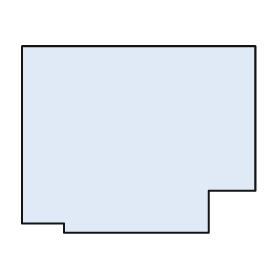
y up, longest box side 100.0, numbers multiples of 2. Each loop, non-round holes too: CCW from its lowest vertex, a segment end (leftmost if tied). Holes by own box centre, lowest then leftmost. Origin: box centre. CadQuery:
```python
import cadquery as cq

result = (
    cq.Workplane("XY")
    .moveTo(-32.0, -40.0)
    .lineTo(30.0, -40.0)
    .lineTo(30.0, -22.0)
    .lineTo(50.0, -22.0)
    .lineTo(50.0, 40.0)
    .lineTo(-50.0, 40.0)
    .lineTo(-50.0, -36.0)
    .lineTo(-32.0, -36.0)
    .close()
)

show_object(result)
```